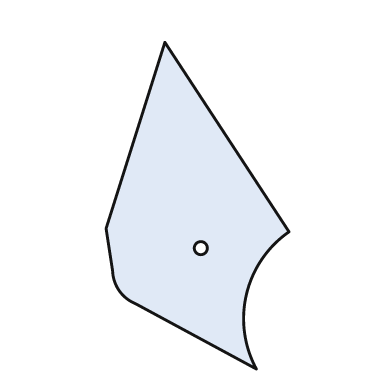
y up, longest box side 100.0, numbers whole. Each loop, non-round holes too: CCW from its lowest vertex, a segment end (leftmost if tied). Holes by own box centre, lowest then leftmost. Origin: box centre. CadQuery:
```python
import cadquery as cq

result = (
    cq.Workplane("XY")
    .moveTo(18.0, -50.0)
    .threePointArc((15.0, -27.0), (28.0, -8.0))
    .lineTo(-10.0, 50.0)
    .lineTo(-28.0, -7.0)
    .lineTo(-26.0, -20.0)
    .threePointArc((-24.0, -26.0), (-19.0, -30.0))
    .close()
    .moveTo(1.0, -13.0)
    .circle(2.0)
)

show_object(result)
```